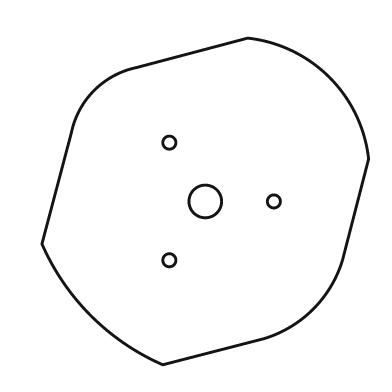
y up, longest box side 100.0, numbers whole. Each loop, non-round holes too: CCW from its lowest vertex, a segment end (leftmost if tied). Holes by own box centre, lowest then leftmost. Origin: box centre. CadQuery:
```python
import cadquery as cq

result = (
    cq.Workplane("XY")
    .moveTo(-13.0, -50.0)
    .lineTo(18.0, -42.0)
    .threePointArc((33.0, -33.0), (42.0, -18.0))
    .lineTo(50.0, 13.0)
    .threePointArc((38.0, 38.0), (13.0, 50.0))
    .lineTo(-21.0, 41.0)
    .threePointArc((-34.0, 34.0), (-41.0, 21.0))
    .lineTo(-50.0, -13.0)
    .threePointArc((-35.0, -35.0), (-13.0, -50.0))
    .close()
    .moveTo(-11.0, -18.0)
    .circle(2.0)
    .moveTo(0.0, 0.0)
    .circle(5.0)
    .moveTo(21.0, 0.0)
    .circle(2.0)
    .moveTo(-11.0, 18.0)
    .circle(2.0)
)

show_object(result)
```